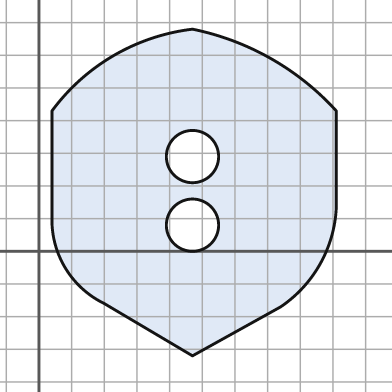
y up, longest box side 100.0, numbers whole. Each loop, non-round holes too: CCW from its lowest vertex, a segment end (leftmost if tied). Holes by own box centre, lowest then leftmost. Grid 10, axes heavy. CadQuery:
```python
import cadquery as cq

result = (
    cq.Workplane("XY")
    .moveTo(47.0, -32.0)
    .lineTo(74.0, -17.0)
    .threePointArc((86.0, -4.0), (91.0, 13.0))
    .lineTo(91.0, 43.0)
    .threePointArc((71.0, 59.0), (47.0, 68.0))
    .threePointArc((23.0, 60.0), (4.0, 43.0))
    .lineTo(4.0, 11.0)
    .threePointArc((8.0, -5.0), (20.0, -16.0))
    .close()
    .moveTo(47.0, 8.0)
    .circle(8.0)
    .moveTo(47.0, 29.0)
    .circle(8.0)
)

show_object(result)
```